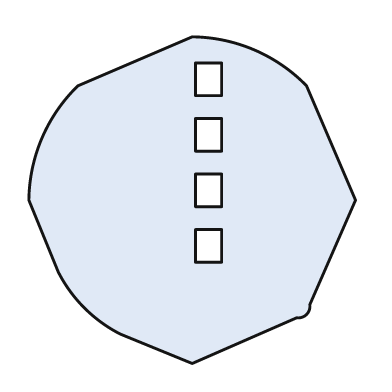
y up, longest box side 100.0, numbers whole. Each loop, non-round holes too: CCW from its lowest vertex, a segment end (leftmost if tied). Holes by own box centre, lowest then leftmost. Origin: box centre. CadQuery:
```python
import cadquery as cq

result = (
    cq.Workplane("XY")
    .moveTo(0.0, -50.0)
    .lineTo(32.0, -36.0)
    .threePointArc((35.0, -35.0), (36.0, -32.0))
    .lineTo(50.0, 0.0)
    .lineTo(35.0, 35.0)
    .threePointArc((19.0, 46.0), (0.0, 50.0))
    .lineTo(-35.0, 35.0)
    .threePointArc((-46.0, 19.0), (-50.0, 0.0))
    .lineTo(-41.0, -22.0)
    .threePointArc((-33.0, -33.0), (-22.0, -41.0))
    .close()
    .moveTo(1.0, -19.0)
    .lineTo(9.0, -19.0)
    .lineTo(9.0, -9.0)
    .lineTo(1.0, -9.0)
    .close()
    .moveTo(1.0, -2.0)
    .lineTo(9.0, -2.0)
    .lineTo(9.0, 8.0)
    .lineTo(1.0, 8.0)
    .close()
    .moveTo(1.0, 15.0)
    .lineTo(9.0, 15.0)
    .lineTo(9.0, 25.0)
    .lineTo(1.0, 25.0)
    .close()
    .moveTo(1.0, 32.0)
    .lineTo(9.0, 32.0)
    .lineTo(9.0, 42.0)
    .lineTo(1.0, 42.0)
    .close()
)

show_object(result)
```